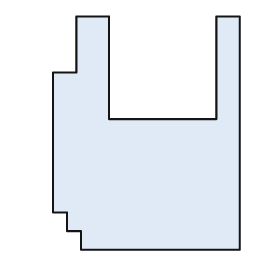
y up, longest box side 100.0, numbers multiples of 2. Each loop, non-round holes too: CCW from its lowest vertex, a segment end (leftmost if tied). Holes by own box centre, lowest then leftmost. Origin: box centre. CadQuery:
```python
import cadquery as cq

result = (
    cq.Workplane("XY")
    .moveTo(-28.0, -50.0)
    .lineTo(40.0, -50.0)
    .lineTo(40.0, 50.0)
    .lineTo(30.0, 50.0)
    .lineTo(30.0, 6.0)
    .lineTo(-16.0, 6.0)
    .lineTo(-16.0, 50.0)
    .lineTo(-30.0, 50.0)
    .lineTo(-30.0, 26.0)
    .lineTo(-40.0, 26.0)
    .lineTo(-40.0, -34.0)
    .lineTo(-34.0, -34.0)
    .lineTo(-34.0, -42.0)
    .lineTo(-28.0, -42.0)
    .close()
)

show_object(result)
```